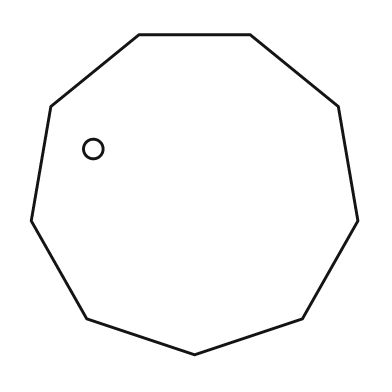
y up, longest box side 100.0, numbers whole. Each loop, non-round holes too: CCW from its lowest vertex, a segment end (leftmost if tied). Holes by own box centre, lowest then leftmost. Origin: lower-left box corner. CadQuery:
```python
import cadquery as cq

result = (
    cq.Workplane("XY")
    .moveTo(50.0, 0.0)
    .lineTo(83.0, 11.0)
    .lineTo(100.0, 41.0)
    .lineTo(94.0, 76.0)
    .lineTo(67.0, 98.0)
    .lineTo(33.0, 98.0)
    .lineTo(6.0, 76.0)
    .lineTo(0.0, 41.0)
    .lineTo(17.0, 11.0)
    .close()
    .moveTo(19.0, 63.0)
    .circle(3.0)
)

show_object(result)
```